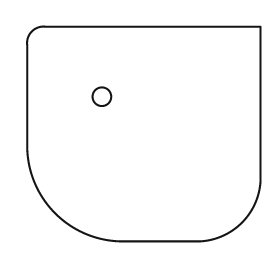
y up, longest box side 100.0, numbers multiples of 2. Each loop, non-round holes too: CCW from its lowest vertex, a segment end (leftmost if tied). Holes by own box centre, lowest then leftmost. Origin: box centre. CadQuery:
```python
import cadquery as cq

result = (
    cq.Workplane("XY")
    .moveTo(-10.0, -46.0)
    .lineTo(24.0, -46.0)
    .threePointArc((42.0, -38.0), (50.0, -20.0))
    .lineTo(50.0, 46.0)
    .lineTo(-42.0, 46.0)
    .threePointArc((-48.0, 44.0), (-50.0, 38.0))
    .lineTo(-50.0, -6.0)
    .threePointArc((-38.0, -34.0), (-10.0, -46.0))
    .close()
    .moveTo(-18.0, 16.0)
    .circle(4.0)
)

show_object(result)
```